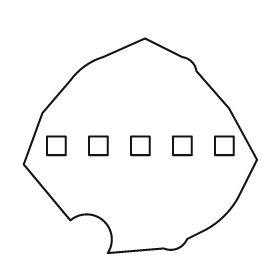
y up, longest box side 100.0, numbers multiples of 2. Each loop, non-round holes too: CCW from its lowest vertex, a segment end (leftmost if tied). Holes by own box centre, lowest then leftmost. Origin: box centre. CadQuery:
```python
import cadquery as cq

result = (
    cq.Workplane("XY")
    .moveTo(-14.0, -46.0)
    .lineTo(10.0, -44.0)
    .threePointArc((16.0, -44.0), (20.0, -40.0))
    .lineTo(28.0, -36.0)
    .threePointArc((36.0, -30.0), (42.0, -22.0))
    .lineTo(50.0, -6.0)
    .lineTo(38.0, 16.0)
    .lineTo(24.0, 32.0)
    .threePointArc((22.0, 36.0), (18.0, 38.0))
    .lineTo(2.0, 46.0)
    .lineTo(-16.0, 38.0)
    .threePointArc((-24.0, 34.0), (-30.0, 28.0))
    .lineTo(-42.0, 14.0)
    .lineTo(-50.0, -8.0)
    .lineTo(-30.0, -32.0)
    .threePointArc((-16.0, -32.0), (-14.0, -46.0))
    .close()
    .moveTo(-40.0, -4.0)
    .lineTo(-32.0, -4.0)
    .lineTo(-32.0, 4.0)
    .lineTo(-40.0, 4.0)
    .close()
    .moveTo(-22.0, -4.0)
    .lineTo(-14.0, -4.0)
    .lineTo(-14.0, 4.0)
    .lineTo(-22.0, 4.0)
    .close()
    .moveTo(-4.0, -4.0)
    .lineTo(4.0, -4.0)
    .lineTo(4.0, 4.0)
    .lineTo(-4.0, 4.0)
    .close()
    .moveTo(14.0, -4.0)
    .lineTo(22.0, -4.0)
    .lineTo(22.0, 4.0)
    .lineTo(14.0, 4.0)
    .close()
    .moveTo(32.0, -4.0)
    .lineTo(40.0, -4.0)
    .lineTo(40.0, 4.0)
    .lineTo(32.0, 4.0)
    .close()
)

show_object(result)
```